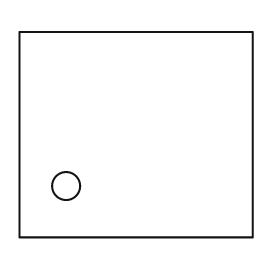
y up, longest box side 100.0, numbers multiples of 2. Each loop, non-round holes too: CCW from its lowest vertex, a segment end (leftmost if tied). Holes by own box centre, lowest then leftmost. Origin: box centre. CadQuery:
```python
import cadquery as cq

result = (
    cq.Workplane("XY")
    .moveTo(-50.0, -44.0)
    .lineTo(50.0, -44.0)
    .lineTo(50.0, 44.0)
    .lineTo(-50.0, 44.0)
    .close()
    .moveTo(-30.0, -22.0)
    .circle(6.0)
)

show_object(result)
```